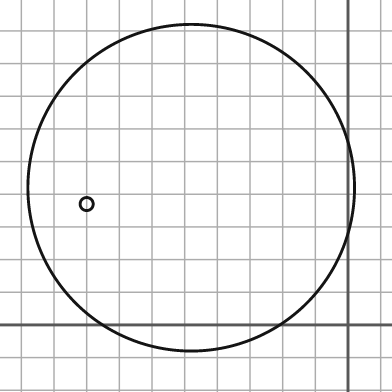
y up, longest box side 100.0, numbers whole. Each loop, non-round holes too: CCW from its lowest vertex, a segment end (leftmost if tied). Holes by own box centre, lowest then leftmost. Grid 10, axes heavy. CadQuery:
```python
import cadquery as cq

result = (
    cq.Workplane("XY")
    .moveTo(-48.0, 42.0)
    .circle(50.0)
    .moveTo(-80.0, 37.0)
    .circle(2.0)
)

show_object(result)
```